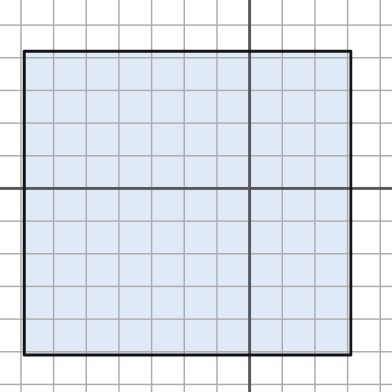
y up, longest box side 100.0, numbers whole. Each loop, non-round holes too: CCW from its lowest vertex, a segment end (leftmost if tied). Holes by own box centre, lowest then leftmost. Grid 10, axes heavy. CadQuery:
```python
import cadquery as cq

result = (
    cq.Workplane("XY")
    .moveTo(-69.0, -51.0)
    .lineTo(31.0, -51.0)
    .lineTo(31.0, 42.0)
    .lineTo(-69.0, 42.0)
    .close()
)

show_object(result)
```